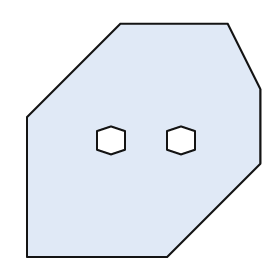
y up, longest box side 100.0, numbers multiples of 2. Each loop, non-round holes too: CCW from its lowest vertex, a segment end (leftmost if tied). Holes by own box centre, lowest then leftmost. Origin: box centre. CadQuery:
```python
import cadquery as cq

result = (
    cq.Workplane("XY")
    .moveTo(-50.0, -50.0)
    .lineTo(10.0, -50.0)
    .lineTo(50.0, -10.0)
    .lineTo(50.0, 22.0)
    .lineTo(36.0, 50.0)
    .lineTo(-10.0, 50.0)
    .lineTo(-50.0, 10.0)
    .close()
    .moveTo(-14.0, -6.0)
    .lineTo(-8.0, -4.0)
    .lineTo(-8.0, 4.0)
    .lineTo(-14.0, 6.0)
    .lineTo(-20.0, 4.0)
    .lineTo(-20.0, -4.0)
    .close()
    .moveTo(16.0, -6.0)
    .lineTo(22.0, -4.0)
    .lineTo(22.0, 4.0)
    .lineTo(16.0, 6.0)
    .lineTo(10.0, 4.0)
    .lineTo(10.0, -4.0)
    .close()
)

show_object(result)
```